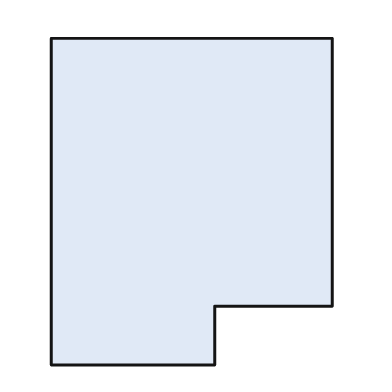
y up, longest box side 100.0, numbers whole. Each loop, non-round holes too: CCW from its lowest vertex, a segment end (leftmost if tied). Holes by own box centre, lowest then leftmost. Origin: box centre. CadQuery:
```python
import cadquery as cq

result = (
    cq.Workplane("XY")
    .moveTo(-43.0, -50.0)
    .lineTo(7.0, -50.0)
    .lineTo(7.0, -32.0)
    .lineTo(43.0, -32.0)
    .lineTo(43.0, 50.0)
    .lineTo(-43.0, 50.0)
    .close()
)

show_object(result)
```